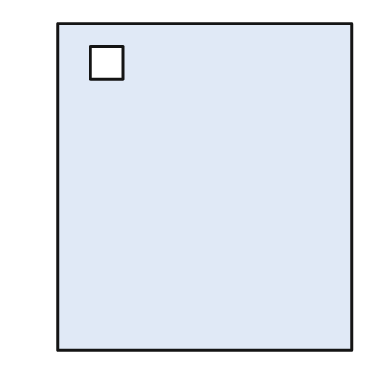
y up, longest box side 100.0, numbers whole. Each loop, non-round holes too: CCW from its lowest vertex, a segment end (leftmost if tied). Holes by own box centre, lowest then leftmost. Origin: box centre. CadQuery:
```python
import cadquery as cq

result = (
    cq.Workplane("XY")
    .moveTo(-45.0, -50.0)
    .lineTo(45.0, -50.0)
    .lineTo(45.0, 50.0)
    .lineTo(-45.0, 50.0)
    .close()
    .moveTo(-35.0, 33.0)
    .lineTo(-25.0, 33.0)
    .lineTo(-25.0, 43.0)
    .lineTo(-35.0, 43.0)
    .close()
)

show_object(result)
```